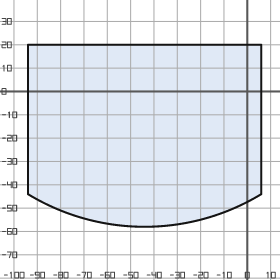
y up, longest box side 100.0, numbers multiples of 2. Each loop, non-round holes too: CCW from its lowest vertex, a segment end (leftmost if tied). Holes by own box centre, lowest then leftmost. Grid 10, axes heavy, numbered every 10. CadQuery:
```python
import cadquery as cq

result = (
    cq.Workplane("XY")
    .moveTo(-94.0, -44.0)
    .threePointArc((-44.0, -58.0), (6.0, -44.0))
    .lineTo(6.0, 20.0)
    .lineTo(-94.0, 20.0)
    .close()
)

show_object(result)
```